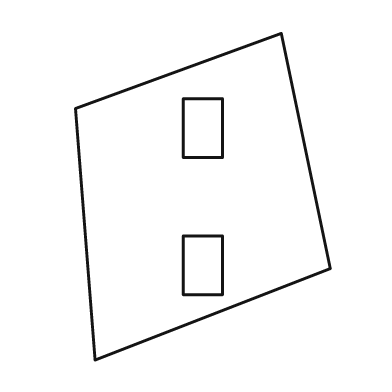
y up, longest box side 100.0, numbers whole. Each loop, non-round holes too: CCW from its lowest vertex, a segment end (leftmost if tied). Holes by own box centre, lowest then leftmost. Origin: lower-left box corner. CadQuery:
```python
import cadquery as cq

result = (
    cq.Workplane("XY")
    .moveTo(6.0, 0.0)
    .lineTo(78.0, 28.0)
    .lineTo(63.0, 100.0)
    .lineTo(0.0, 77.0)
    .close()
    .moveTo(33.0, 20.0)
    .lineTo(45.0, 20.0)
    .lineTo(45.0, 38.0)
    .lineTo(33.0, 38.0)
    .close()
    .moveTo(33.0, 62.0)
    .lineTo(45.0, 62.0)
    .lineTo(45.0, 80.0)
    .lineTo(33.0, 80.0)
    .close()
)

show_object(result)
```